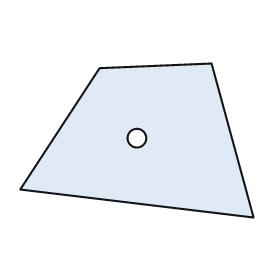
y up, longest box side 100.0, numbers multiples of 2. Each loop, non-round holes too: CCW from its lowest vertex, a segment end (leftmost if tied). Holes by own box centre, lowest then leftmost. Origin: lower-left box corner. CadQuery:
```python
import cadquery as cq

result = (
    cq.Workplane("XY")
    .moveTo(100.0, 0.0)
    .lineTo(82.0, 66.0)
    .lineTo(34.0, 64.0)
    .lineTo(0.0, 12.0)
    .close()
    .moveTo(50.0, 34.0)
    .circle(4.0)
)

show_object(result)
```